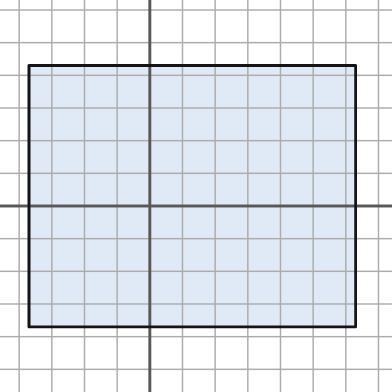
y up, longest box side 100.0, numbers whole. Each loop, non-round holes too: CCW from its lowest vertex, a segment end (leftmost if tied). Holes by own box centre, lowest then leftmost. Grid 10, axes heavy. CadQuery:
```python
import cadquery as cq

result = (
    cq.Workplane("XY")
    .moveTo(-37.0, -37.0)
    .lineTo(63.0, -37.0)
    .lineTo(63.0, 43.0)
    .lineTo(-37.0, 43.0)
    .close()
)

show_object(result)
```